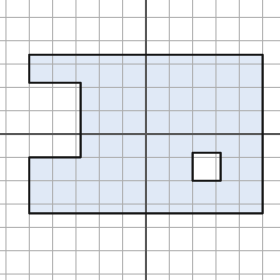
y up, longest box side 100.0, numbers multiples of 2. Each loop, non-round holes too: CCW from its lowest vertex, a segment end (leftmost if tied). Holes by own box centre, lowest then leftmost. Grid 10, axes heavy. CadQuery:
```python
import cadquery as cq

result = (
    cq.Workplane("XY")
    .moveTo(-50.0, -34.0)
    .lineTo(50.0, -34.0)
    .lineTo(50.0, 34.0)
    .lineTo(-50.0, 34.0)
    .lineTo(-50.0, 22.0)
    .lineTo(-28.0, 22.0)
    .lineTo(-28.0, -10.0)
    .lineTo(-50.0, -10.0)
    .close()
    .moveTo(20.0, -20.0)
    .lineTo(32.0, -20.0)
    .lineTo(32.0, -8.0)
    .lineTo(20.0, -8.0)
    .close()
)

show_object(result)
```